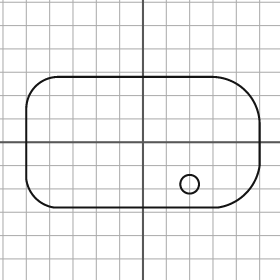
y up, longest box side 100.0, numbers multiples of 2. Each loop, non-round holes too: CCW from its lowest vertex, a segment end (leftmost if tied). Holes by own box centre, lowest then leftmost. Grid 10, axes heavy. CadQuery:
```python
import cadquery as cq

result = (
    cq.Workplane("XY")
    .moveTo(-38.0, -28.0)
    .lineTo(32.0, -28.0)
    .threePointArc((44.0, -22.0), (50.0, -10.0))
    .lineTo(50.0, 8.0)
    .threePointArc((44.0, 22.0), (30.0, 28.0))
    .lineTo(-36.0, 28.0)
    .threePointArc((-46.0, 24.0), (-50.0, 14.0))
    .lineTo(-50.0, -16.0)
    .threePointArc((-46.0, -24.0), (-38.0, -28.0))
    .close()
    .moveTo(20.0, -18.0)
    .circle(4.0)
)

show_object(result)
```